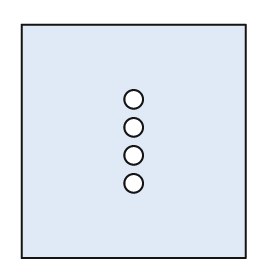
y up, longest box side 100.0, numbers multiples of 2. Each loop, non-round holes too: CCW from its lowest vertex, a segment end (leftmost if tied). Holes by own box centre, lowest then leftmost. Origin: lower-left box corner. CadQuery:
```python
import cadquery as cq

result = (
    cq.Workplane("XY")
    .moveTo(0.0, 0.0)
    .lineTo(96.0, 0.0)
    .lineTo(96.0, 100.0)
    .lineTo(0.0, 100.0)
    .close()
    .moveTo(48.0, 32.0)
    .circle(4.0)
    .moveTo(48.0, 44.0)
    .circle(4.0)
    .moveTo(48.0, 56.0)
    .circle(4.0)
    .moveTo(48.0, 68.0)
    .circle(4.0)
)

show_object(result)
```